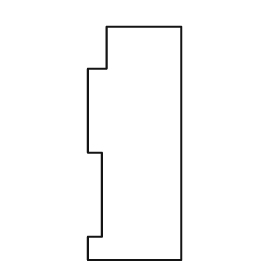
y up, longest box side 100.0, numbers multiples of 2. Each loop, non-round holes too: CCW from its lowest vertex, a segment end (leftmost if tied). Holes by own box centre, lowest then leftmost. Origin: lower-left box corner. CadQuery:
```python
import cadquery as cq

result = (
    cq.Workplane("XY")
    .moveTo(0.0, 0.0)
    .lineTo(40.0, 0.0)
    .lineTo(40.0, 100.0)
    .lineTo(8.0, 100.0)
    .lineTo(8.0, 82.0)
    .lineTo(0.0, 82.0)
    .lineTo(0.0, 46.0)
    .lineTo(6.0, 46.0)
    .lineTo(6.0, 10.0)
    .lineTo(0.0, 10.0)
    .close()
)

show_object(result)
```